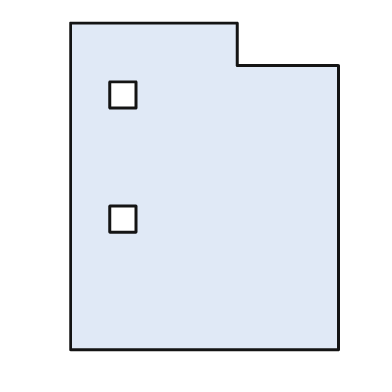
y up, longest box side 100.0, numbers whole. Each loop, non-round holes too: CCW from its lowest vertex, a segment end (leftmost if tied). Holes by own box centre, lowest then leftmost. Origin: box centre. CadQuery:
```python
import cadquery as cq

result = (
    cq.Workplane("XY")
    .moveTo(-41.0, -50.0)
    .lineTo(41.0, -50.0)
    .lineTo(41.0, 37.0)
    .lineTo(10.0, 37.0)
    .lineTo(10.0, 50.0)
    .lineTo(-41.0, 50.0)
    .close()
    .moveTo(-29.0, -14.0)
    .lineTo(-21.0, -14.0)
    .lineTo(-21.0, -6.0)
    .lineTo(-29.0, -6.0)
    .close()
    .moveTo(-29.0, 24.0)
    .lineTo(-21.0, 24.0)
    .lineTo(-21.0, 32.0)
    .lineTo(-29.0, 32.0)
    .close()
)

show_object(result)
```